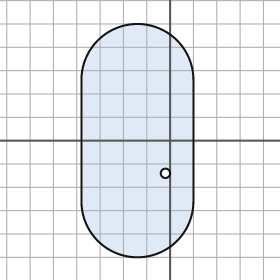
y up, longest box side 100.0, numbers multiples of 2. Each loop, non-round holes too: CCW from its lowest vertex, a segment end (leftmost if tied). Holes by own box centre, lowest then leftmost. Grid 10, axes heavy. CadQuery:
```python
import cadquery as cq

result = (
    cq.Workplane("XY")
    .moveTo(-38.0, -26.0)
    .threePointArc((-14.0, -50.0), (10.0, -26.0))
    .lineTo(10.0, 26.0)
    .threePointArc((-14.0, 50.0), (-38.0, 26.0))
    .close()
    .moveTo(-2.0, -14.0)
    .circle(2.0)
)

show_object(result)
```